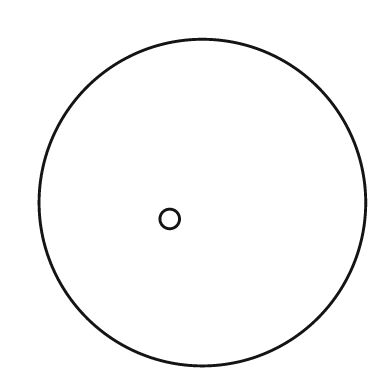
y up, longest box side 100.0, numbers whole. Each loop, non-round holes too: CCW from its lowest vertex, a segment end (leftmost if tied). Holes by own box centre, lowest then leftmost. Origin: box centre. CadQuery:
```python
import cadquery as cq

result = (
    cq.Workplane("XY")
    .moveTo(0.0, 0.0)
    .circle(50.0)
    .moveTo(-10.0, -5.0)
    .circle(3.0)
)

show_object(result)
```